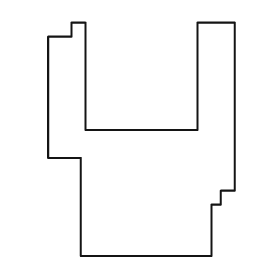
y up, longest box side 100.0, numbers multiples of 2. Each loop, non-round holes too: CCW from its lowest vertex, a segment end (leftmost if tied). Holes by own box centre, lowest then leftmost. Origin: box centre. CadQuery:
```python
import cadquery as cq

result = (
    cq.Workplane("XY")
    .moveTo(-26.0, -50.0)
    .lineTo(30.0, -50.0)
    .lineTo(30.0, -28.0)
    .lineTo(34.0, -28.0)
    .lineTo(34.0, -22.0)
    .lineTo(40.0, -22.0)
    .lineTo(40.0, 50.0)
    .lineTo(24.0, 50.0)
    .lineTo(24.0, 4.0)
    .lineTo(-24.0, 4.0)
    .lineTo(-24.0, 50.0)
    .lineTo(-30.0, 50.0)
    .lineTo(-30.0, 44.0)
    .lineTo(-40.0, 44.0)
    .lineTo(-40.0, -8.0)
    .lineTo(-26.0, -8.0)
    .close()
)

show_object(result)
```